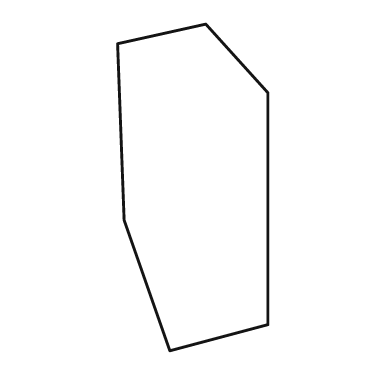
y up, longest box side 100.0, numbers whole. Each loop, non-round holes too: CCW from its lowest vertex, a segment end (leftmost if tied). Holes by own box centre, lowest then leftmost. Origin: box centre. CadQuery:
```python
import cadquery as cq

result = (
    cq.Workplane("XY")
    .moveTo(-7.0, -50.0)
    .lineTo(23.0, -42.0)
    .lineTo(23.0, 29.0)
    .lineTo(4.0, 50.0)
    .lineTo(-23.0, 44.0)
    .lineTo(-21.0, -10.0)
    .close()
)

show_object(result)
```